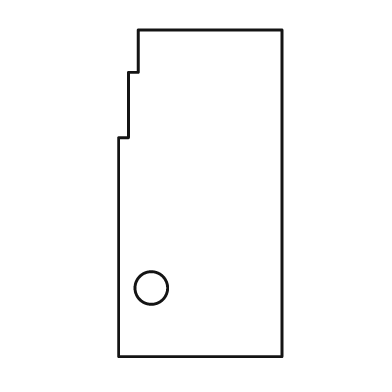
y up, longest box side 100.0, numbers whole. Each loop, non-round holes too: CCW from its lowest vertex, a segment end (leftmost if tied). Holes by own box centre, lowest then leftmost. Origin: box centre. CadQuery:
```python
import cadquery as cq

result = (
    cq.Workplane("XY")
    .moveTo(-25.0, -50.0)
    .lineTo(25.0, -50.0)
    .lineTo(25.0, 50.0)
    .lineTo(-19.0, 50.0)
    .lineTo(-19.0, 37.0)
    .lineTo(-22.0, 37.0)
    .lineTo(-22.0, 17.0)
    .lineTo(-25.0, 17.0)
    .close()
    .moveTo(-15.0, -29.0)
    .circle(5.0)
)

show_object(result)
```